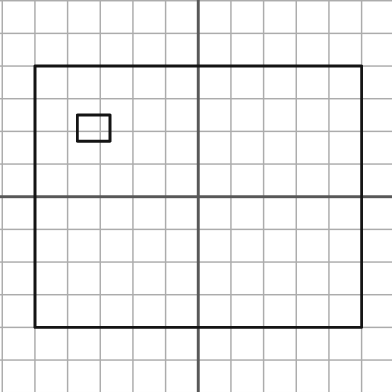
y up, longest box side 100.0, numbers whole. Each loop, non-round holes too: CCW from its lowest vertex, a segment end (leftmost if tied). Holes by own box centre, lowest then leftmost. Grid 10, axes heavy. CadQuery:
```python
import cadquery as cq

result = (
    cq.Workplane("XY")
    .moveTo(-50.0, -40.0)
    .lineTo(50.0, -40.0)
    .lineTo(50.0, 40.0)
    .lineTo(-50.0, 40.0)
    .close()
    .moveTo(-37.0, 17.0)
    .lineTo(-27.0, 17.0)
    .lineTo(-27.0, 25.0)
    .lineTo(-37.0, 25.0)
    .close()
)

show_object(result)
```